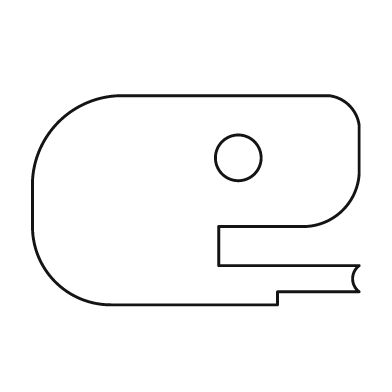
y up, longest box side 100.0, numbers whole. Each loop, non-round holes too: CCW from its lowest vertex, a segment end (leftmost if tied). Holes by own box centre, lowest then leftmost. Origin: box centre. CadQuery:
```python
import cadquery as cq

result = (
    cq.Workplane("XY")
    .moveTo(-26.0, -32.0)
    .lineTo(25.0, -32.0)
    .lineTo(25.0, -28.0)
    .lineTo(50.0, -28.0)
    .threePointArc((48.0, -24.0), (50.0, -20.0))
    .lineTo(7.0, -20.0)
    .lineTo(7.0, -8.0)
    .lineTo(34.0, -8.0)
    .threePointArc((45.0, -3.0), (50.0, 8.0))
    .lineTo(50.0, 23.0)
    .threePointArc((47.0, 29.0), (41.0, 32.0))
    .lineTo(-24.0, 32.0)
    .threePointArc((-42.0, 24.0), (-50.0, 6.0))
    .lineTo(-50.0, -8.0)
    .threePointArc((-43.0, -25.0), (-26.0, -32.0))
    .close()
    .moveTo(13.0, 13.0)
    .circle(7.0)
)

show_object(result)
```